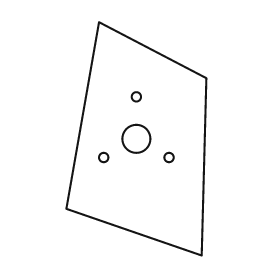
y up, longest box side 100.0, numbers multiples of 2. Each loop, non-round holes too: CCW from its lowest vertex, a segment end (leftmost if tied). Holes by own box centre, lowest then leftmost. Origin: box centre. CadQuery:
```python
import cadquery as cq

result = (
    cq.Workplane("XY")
    .moveTo(28.0, -50.0)
    .lineTo(30.0, 26.0)
    .lineTo(-16.0, 50.0)
    .lineTo(-30.0, -30.0)
    .close()
    .moveTo(-14.0, -8.0)
    .circle(2.0)
    .moveTo(14.0, -8.0)
    .circle(2.0)
    .moveTo(0.0, 0.0)
    .circle(6.0)
    .moveTo(0.0, 18.0)
    .circle(2.0)
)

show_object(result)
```